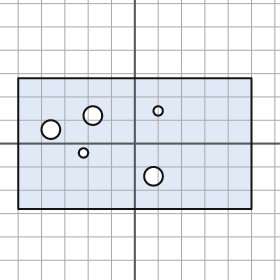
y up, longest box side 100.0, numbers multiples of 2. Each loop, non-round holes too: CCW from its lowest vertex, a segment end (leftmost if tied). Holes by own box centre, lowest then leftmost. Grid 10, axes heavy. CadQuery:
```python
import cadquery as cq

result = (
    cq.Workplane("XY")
    .moveTo(-50.0, -28.0)
    .lineTo(50.0, -28.0)
    .lineTo(50.0, 28.0)
    .lineTo(-50.0, 28.0)
    .close()
    .moveTo(8.0, -14.0)
    .circle(4.0)
    .moveTo(-22.0, -4.0)
    .circle(2.0)
    .moveTo(-36.0, 6.0)
    .circle(4.0)
    .moveTo(-18.0, 12.0)
    .circle(4.0)
    .moveTo(10.0, 14.0)
    .circle(2.0)
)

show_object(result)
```